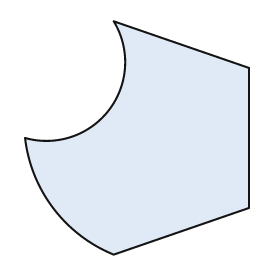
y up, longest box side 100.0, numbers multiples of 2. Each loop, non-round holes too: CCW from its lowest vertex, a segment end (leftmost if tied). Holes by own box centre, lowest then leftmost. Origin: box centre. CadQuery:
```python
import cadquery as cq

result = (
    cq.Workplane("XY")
    .moveTo(-10.0, -50.0)
    .lineTo(48.0, -30.0)
    .lineTo(48.0, 30.0)
    .lineTo(-10.0, 50.0)
    .threePointArc((-12.0, 12.0), (-48.0, 0.0))
    .threePointArc((-36.0, -30.0), (-10.0, -50.0))
    .close()
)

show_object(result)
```